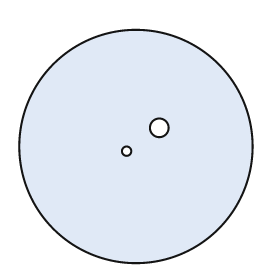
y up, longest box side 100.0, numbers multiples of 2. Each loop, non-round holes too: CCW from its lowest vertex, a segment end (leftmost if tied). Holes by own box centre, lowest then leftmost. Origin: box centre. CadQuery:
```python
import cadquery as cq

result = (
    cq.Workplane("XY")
    .moveTo(0.0, 0.0)
    .circle(50.0)
    .moveTo(-4.0, -2.0)
    .circle(2.0)
    .moveTo(10.0, 8.0)
    .circle(4.0)
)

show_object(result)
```